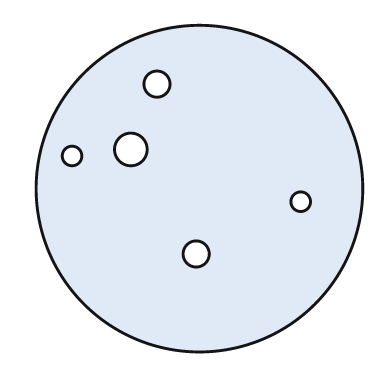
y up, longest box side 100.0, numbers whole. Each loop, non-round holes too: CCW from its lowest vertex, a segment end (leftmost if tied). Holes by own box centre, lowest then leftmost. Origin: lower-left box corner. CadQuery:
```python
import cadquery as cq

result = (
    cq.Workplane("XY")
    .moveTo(50.0, 50.0)
    .circle(50.0)
    .moveTo(49.0, 30.0)
    .circle(4.0)
    .moveTo(81.0, 46.0)
    .circle(3.0)
    .moveTo(11.0, 60.0)
    .circle(3.0)
    .moveTo(29.0, 62.0)
    .circle(5.0)
    .moveTo(37.0, 82.0)
    .circle(4.0)
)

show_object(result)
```